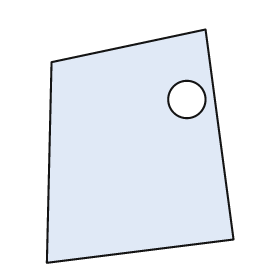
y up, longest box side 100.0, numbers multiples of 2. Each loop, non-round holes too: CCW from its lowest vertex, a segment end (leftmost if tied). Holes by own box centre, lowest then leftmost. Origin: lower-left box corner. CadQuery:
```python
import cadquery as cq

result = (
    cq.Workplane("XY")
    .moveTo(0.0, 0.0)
    .lineTo(80.0, 10.0)
    .lineTo(68.0, 100.0)
    .lineTo(2.0, 86.0)
    .close()
    .moveTo(60.0, 70.0)
    .circle(8.0)
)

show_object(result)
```